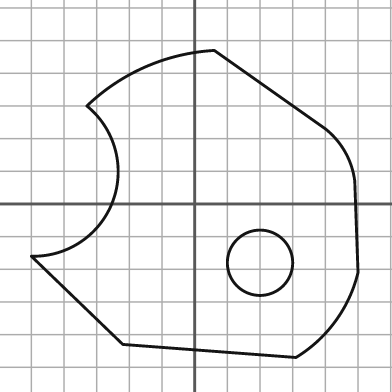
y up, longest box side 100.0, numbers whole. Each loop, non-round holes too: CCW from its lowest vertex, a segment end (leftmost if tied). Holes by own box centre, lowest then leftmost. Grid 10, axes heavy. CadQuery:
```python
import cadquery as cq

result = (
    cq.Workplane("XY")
    .moveTo(31.0, -47.0)
    .threePointArc((43.0, -36.0), (50.0, -21.0))
    .lineTo(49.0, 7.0)
    .threePointArc((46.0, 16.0), (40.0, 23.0))
    .lineTo(6.0, 47.0)
    .threePointArc((-15.0, 42.0), (-33.0, 30.0))
    .threePointArc((-25.0, 1.0), (-50.0, -16.0))
    .lineTo(-22.0, -43.0)
    .close()
    .moveTo(20.0, -18.0)
    .circle(10.0)
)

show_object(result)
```